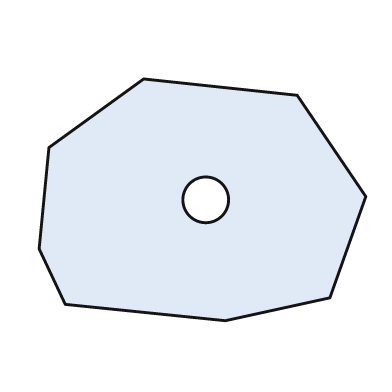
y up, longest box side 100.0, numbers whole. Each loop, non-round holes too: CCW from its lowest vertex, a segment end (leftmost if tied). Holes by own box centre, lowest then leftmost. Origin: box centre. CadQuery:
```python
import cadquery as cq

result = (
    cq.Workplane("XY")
    .moveTo(7.0, -37.0)
    .lineTo(39.0, -30.0)
    .lineTo(50.0, 1.0)
    .lineTo(29.0, 32.0)
    .lineTo(-18.0, 37.0)
    .lineTo(-47.0, 16.0)
    .lineTo(-50.0, -15.0)
    .lineTo(-42.0, -32.0)
    .close()
    .moveTo(1.0, 0.0)
    .circle(7.0)
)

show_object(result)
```